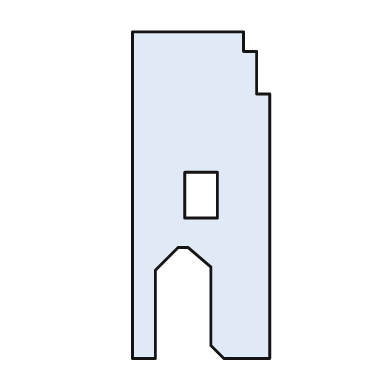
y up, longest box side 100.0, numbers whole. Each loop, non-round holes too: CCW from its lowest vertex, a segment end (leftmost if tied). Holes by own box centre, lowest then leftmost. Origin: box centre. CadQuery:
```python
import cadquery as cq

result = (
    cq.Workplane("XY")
    .moveTo(-21.0, -50.0)
    .lineTo(-14.0, -50.0)
    .lineTo(-14.0, -23.0)
    .lineTo(-7.0, -16.0)
    .lineTo(-4.0, -16.0)
    .lineTo(3.0, -22.0)
    .lineTo(3.0, -46.0)
    .lineTo(7.0, -50.0)
    .lineTo(21.0, -50.0)
    .lineTo(21.0, 31.0)
    .lineTo(17.0, 31.0)
    .lineTo(17.0, 44.0)
    .lineTo(13.0, 44.0)
    .lineTo(13.0, 50.0)
    .lineTo(-21.0, 50.0)
    .close()
    .moveTo(-5.0, -7.0)
    .lineTo(5.0, -7.0)
    .lineTo(5.0, 7.0)
    .lineTo(-5.0, 7.0)
    .close()
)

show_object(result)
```